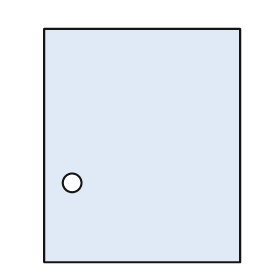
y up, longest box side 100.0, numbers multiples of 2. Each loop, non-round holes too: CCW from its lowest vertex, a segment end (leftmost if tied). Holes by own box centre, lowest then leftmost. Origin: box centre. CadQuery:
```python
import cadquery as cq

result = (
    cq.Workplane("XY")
    .moveTo(-42.0, -50.0)
    .lineTo(42.0, -50.0)
    .lineTo(42.0, 50.0)
    .lineTo(-42.0, 50.0)
    .close()
    .moveTo(-30.0, -16.0)
    .circle(4.0)
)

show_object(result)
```